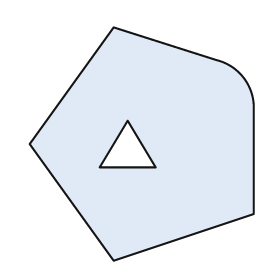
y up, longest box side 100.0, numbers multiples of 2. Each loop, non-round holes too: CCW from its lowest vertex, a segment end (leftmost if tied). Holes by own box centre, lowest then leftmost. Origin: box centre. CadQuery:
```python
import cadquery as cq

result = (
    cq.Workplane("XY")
    .moveTo(-12.0, -50.0)
    .lineTo(48.0, -30.0)
    .lineTo(48.0, 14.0)
    .threePointArc((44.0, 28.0), (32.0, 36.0))
    .lineTo(-12.0, 50.0)
    .lineTo(-48.0, 0.0)
    .close()
    .moveTo(-18.0, -10.0)
    .lineTo(6.0, -10.0)
    .lineTo(-6.0, 10.0)
    .close()
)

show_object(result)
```